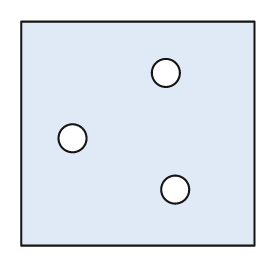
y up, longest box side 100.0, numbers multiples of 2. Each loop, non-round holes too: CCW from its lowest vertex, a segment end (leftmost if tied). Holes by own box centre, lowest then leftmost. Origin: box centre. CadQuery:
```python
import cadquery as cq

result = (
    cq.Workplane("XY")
    .moveTo(-50.0, -48.0)
    .lineTo(50.0, -48.0)
    .lineTo(50.0, 48.0)
    .lineTo(-50.0, 48.0)
    .close()
    .moveTo(16.0, -24.0)
    .circle(6.0)
    .moveTo(-28.0, -2.0)
    .circle(6.0)
    .moveTo(12.0, 26.0)
    .circle(6.0)
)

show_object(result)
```